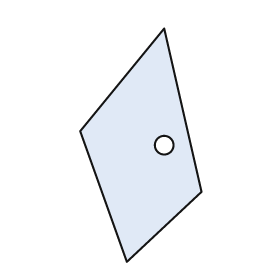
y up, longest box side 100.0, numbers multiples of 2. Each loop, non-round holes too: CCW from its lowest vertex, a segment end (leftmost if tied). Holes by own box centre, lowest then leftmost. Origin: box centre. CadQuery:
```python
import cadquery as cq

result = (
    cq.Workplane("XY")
    .moveTo(-6.0, -50.0)
    .lineTo(26.0, -20.0)
    .lineTo(10.0, 50.0)
    .lineTo(-26.0, 6.0)
    .close()
    .moveTo(10.0, 0.0)
    .circle(4.0)
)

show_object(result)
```